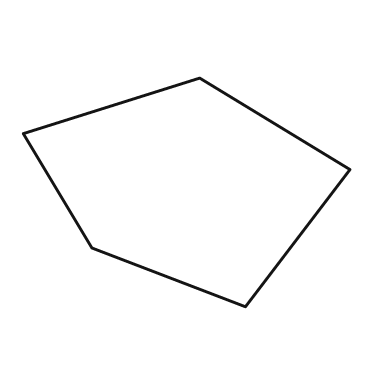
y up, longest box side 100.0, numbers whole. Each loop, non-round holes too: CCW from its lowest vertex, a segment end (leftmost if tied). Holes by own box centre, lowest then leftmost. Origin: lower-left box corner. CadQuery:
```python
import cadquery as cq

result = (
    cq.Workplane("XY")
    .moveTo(68.0, 0.0)
    .lineTo(100.0, 42.0)
    .lineTo(54.0, 70.0)
    .lineTo(0.0, 53.0)
    .lineTo(21.0, 18.0)
    .close()
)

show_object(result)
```